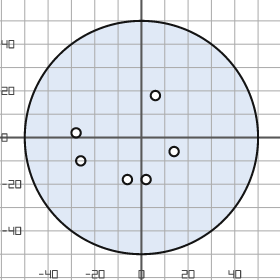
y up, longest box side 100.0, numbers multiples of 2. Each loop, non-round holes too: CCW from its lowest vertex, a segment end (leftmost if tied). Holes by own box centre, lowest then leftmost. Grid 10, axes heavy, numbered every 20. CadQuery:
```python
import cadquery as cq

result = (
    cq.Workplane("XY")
    .moveTo(0.0, 0.0)
    .circle(50.0)
    .moveTo(-6.0, -18.0)
    .circle(2.0)
    .moveTo(2.0, -18.0)
    .circle(2.0)
    .moveTo(-26.0, -10.0)
    .circle(2.0)
    .moveTo(14.0, -6.0)
    .circle(2.0)
    .moveTo(-28.0, 2.0)
    .circle(2.0)
    .moveTo(6.0, 18.0)
    .circle(2.0)
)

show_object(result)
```